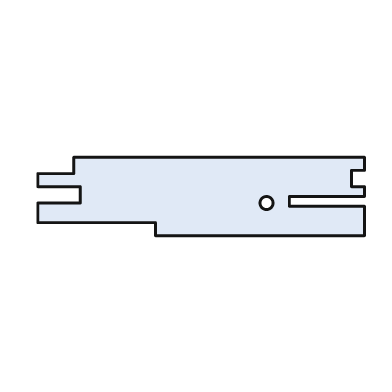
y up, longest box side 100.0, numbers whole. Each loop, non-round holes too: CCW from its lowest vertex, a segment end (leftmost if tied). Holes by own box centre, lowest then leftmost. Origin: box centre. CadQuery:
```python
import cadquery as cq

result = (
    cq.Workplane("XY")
    .moveTo(-14.0, -12.0)
    .lineTo(50.0, -12.0)
    .lineTo(50.0, -3.0)
    .lineTo(27.0, -3.0)
    .lineTo(27.0, 0.0)
    .lineTo(50.0, 0.0)
    .lineTo(50.0, 3.0)
    .lineTo(46.0, 3.0)
    .lineTo(46.0, 8.0)
    .lineTo(50.0, 8.0)
    .lineTo(50.0, 12.0)
    .lineTo(-39.0, 12.0)
    .lineTo(-39.0, 7.0)
    .lineTo(-50.0, 7.0)
    .lineTo(-50.0, 3.0)
    .lineTo(-37.0, 3.0)
    .lineTo(-37.0, -2.0)
    .lineTo(-50.0, -2.0)
    .lineTo(-50.0, -8.0)
    .lineTo(-14.0, -8.0)
    .close()
    .moveTo(20.0, -2.0)
    .circle(2.0)
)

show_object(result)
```